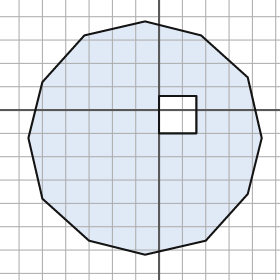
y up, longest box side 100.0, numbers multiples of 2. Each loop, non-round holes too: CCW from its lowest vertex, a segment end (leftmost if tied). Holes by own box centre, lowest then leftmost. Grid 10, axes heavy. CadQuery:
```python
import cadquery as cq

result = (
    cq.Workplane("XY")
    .moveTo(-6.0, -62.0)
    .lineTo(20.0, -56.0)
    .lineTo(38.0, -36.0)
    .lineTo(44.0, -12.0)
    .lineTo(38.0, 14.0)
    .lineTo(18.0, 32.0)
    .lineTo(-6.0, 38.0)
    .lineTo(-32.0, 32.0)
    .lineTo(-50.0, 12.0)
    .lineTo(-56.0, -12.0)
    .lineTo(-50.0, -38.0)
    .lineTo(-30.0, -56.0)
    .close()
    .moveTo(0.0, -10.0)
    .lineTo(16.0, -10.0)
    .lineTo(16.0, 6.0)
    .lineTo(0.0, 6.0)
    .close()
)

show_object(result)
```